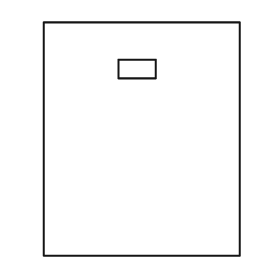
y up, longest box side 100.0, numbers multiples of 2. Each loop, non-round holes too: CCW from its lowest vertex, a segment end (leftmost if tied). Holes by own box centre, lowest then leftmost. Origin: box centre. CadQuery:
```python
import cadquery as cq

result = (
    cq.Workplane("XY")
    .moveTo(-42.0, -50.0)
    .lineTo(42.0, -50.0)
    .lineTo(42.0, 50.0)
    .lineTo(-42.0, 50.0)
    .close()
    .moveTo(-10.0, 26.0)
    .lineTo(6.0, 26.0)
    .lineTo(6.0, 34.0)
    .lineTo(-10.0, 34.0)
    .close()
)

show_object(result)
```